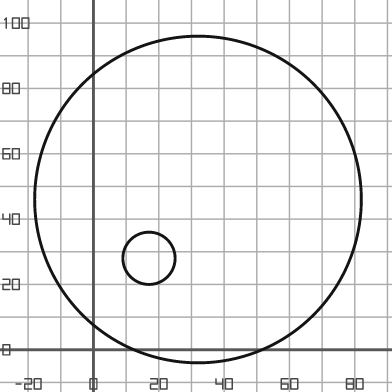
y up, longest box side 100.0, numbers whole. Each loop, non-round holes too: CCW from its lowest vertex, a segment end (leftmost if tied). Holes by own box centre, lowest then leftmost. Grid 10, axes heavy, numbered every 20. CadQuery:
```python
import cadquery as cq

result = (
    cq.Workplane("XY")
    .moveTo(32.0, 46.0)
    .circle(50.0)
    .moveTo(17.0, 28.0)
    .circle(8.0)
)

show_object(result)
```